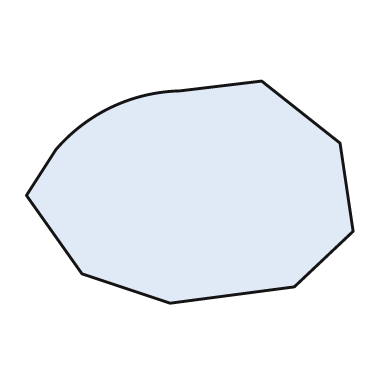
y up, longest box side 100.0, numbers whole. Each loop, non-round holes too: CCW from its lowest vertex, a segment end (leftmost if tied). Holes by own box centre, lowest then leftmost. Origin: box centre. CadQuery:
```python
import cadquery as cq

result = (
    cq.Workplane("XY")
    .moveTo(-6.0, -34.0)
    .lineTo(32.0, -29.0)
    .lineTo(50.0, -12.0)
    .lineTo(46.0, 15.0)
    .lineTo(22.0, 34.0)
    .lineTo(-3.0, 31.0)
    .threePointArc((-24.0, 26.0), (-41.0, 13.0))
    .lineTo(-50.0, -1.0)
    .lineTo(-33.0, -25.0)
    .close()
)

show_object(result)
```